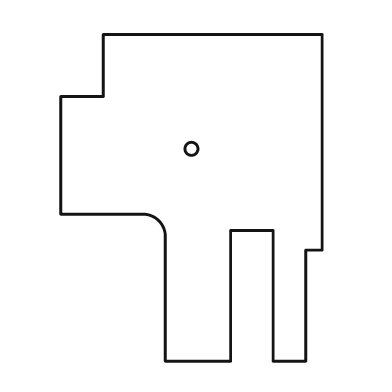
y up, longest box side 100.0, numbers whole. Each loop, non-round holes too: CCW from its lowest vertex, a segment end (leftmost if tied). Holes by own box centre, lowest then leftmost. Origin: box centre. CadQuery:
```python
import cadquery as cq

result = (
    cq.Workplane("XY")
    .moveTo(-8.0, -50.0)
    .lineTo(12.0, -50.0)
    .lineTo(12.0, -10.0)
    .lineTo(25.0, -10.0)
    .lineTo(25.0, -50.0)
    .lineTo(35.0, -50.0)
    .lineTo(35.0, -16.0)
    .lineTo(40.0, -16.0)
    .lineTo(40.0, 50.0)
    .lineTo(-27.0, 50.0)
    .lineTo(-27.0, 31.0)
    .lineTo(-40.0, 31.0)
    .lineTo(-40.0, -5.0)
    .lineTo(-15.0, -5.0)
    .threePointArc((-10.0, -7.0), (-8.0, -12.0))
    .close()
    .moveTo(0.0, 15.0)
    .circle(2.0)
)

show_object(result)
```